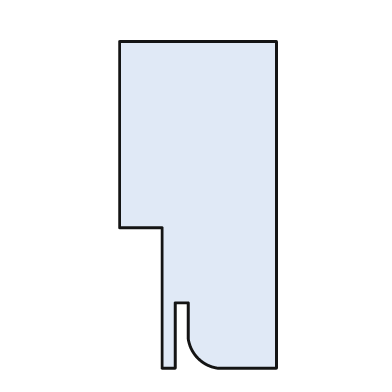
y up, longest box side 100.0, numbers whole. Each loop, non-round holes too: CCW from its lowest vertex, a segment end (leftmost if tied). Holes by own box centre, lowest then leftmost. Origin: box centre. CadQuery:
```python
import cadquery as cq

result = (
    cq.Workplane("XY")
    .moveTo(-11.0, -50.0)
    .lineTo(-7.0, -50.0)
    .lineTo(-7.0, -30.0)
    .lineTo(-3.0, -30.0)
    .lineTo(-3.0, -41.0)
    .threePointArc((0.0, -47.0), (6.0, -50.0))
    .lineTo(24.0, -50.0)
    .lineTo(24.0, 50.0)
    .lineTo(-24.0, 50.0)
    .lineTo(-24.0, -7.0)
    .lineTo(-11.0, -7.0)
    .close()
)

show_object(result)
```